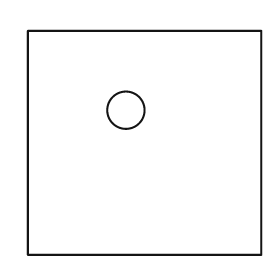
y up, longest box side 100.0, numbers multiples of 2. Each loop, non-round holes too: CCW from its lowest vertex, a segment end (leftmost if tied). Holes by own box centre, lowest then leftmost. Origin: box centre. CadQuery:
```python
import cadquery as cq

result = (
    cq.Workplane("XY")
    .moveTo(-50.0, -48.0)
    .lineTo(50.0, -48.0)
    .lineTo(50.0, 48.0)
    .lineTo(-50.0, 48.0)
    .close()
    .moveTo(-8.0, 14.0)
    .circle(8.0)
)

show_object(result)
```